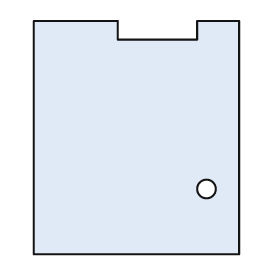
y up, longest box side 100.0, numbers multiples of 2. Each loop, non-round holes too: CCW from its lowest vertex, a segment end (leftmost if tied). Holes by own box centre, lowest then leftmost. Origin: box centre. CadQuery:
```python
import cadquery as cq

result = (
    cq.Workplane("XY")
    .moveTo(-44.0, -50.0)
    .lineTo(44.0, -50.0)
    .lineTo(44.0, 50.0)
    .lineTo(26.0, 50.0)
    .lineTo(26.0, 42.0)
    .lineTo(-8.0, 42.0)
    .lineTo(-8.0, 50.0)
    .lineTo(-44.0, 50.0)
    .close()
    .moveTo(30.0, -22.0)
    .circle(4.0)
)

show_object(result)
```